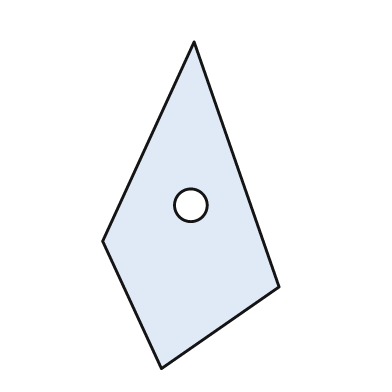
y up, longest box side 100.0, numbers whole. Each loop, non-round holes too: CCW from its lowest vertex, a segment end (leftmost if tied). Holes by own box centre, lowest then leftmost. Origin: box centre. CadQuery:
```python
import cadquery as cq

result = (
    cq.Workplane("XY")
    .moveTo(-9.0, -50.0)
    .lineTo(27.0, -25.0)
    .lineTo(1.0, 50.0)
    .lineTo(-27.0, -11.0)
    .close()
    .moveTo(0.0, 0.0)
    .circle(5.0)
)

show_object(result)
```